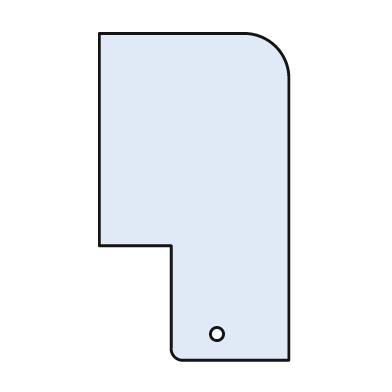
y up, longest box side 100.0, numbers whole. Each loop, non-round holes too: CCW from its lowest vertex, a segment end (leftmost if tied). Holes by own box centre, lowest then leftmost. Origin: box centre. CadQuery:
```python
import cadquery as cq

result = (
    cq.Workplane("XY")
    .moveTo(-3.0, -50.0)
    .lineTo(29.0, -50.0)
    .lineTo(29.0, 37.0)
    .threePointArc((25.0, 46.0), (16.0, 50.0))
    .lineTo(-29.0, 50.0)
    .lineTo(-29.0, -15.0)
    .lineTo(-7.0, -15.0)
    .lineTo(-7.0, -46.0)
    .threePointArc((-6.0, -49.0), (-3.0, -50.0))
    .close()
    .moveTo(7.0, -42.0)
    .circle(2.0)
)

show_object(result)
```